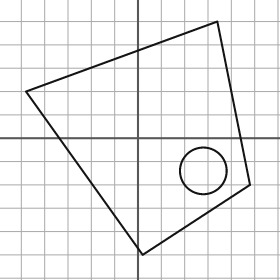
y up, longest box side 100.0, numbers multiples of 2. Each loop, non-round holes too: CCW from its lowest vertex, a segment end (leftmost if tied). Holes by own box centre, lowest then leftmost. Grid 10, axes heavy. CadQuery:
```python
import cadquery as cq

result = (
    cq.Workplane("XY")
    .moveTo(2.0, -50.0)
    .lineTo(48.0, -20.0)
    .lineTo(34.0, 50.0)
    .lineTo(-48.0, 20.0)
    .close()
    .moveTo(28.0, -14.0)
    .circle(10.0)
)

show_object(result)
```